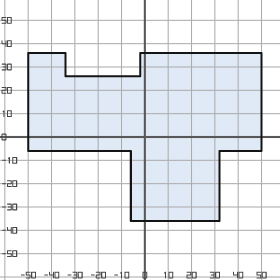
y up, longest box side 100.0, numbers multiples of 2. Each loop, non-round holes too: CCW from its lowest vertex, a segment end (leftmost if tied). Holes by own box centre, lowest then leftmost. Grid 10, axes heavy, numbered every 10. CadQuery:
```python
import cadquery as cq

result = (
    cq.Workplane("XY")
    .moveTo(-6.0, -36.0)
    .lineTo(32.0, -36.0)
    .lineTo(32.0, -6.0)
    .lineTo(50.0, -6.0)
    .lineTo(50.0, 36.0)
    .lineTo(-2.0, 36.0)
    .lineTo(-2.0, 26.0)
    .lineTo(-34.0, 26.0)
    .lineTo(-34.0, 36.0)
    .lineTo(-50.0, 36.0)
    .lineTo(-50.0, -6.0)
    .lineTo(-6.0, -6.0)
    .close()
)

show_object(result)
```